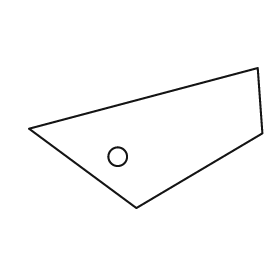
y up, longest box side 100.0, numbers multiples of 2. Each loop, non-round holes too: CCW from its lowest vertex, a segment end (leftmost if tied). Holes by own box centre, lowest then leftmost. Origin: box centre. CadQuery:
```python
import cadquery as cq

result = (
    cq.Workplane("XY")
    .moveTo(-4.0, -30.0)
    .lineTo(50.0, 2.0)
    .lineTo(48.0, 30.0)
    .lineTo(-50.0, 4.0)
    .close()
    .moveTo(-12.0, -8.0)
    .circle(4.0)
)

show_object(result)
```